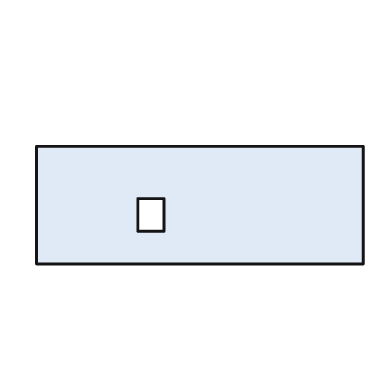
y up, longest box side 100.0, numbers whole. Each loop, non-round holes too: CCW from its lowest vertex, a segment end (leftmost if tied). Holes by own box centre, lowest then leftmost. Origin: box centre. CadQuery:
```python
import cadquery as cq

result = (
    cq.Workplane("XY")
    .moveTo(-50.0, -18.0)
    .lineTo(50.0, -18.0)
    .lineTo(50.0, 18.0)
    .lineTo(-50.0, 18.0)
    .close()
    .moveTo(-19.0, -8.0)
    .lineTo(-11.0, -8.0)
    .lineTo(-11.0, 2.0)
    .lineTo(-19.0, 2.0)
    .close()
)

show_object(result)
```